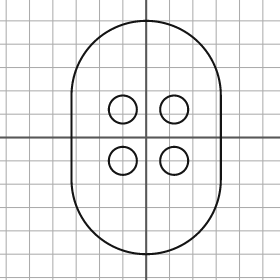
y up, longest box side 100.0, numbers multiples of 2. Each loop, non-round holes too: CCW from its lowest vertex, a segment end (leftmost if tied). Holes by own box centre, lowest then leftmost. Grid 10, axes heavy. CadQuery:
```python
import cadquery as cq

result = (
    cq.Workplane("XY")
    .moveTo(-32.0, -18.0)
    .threePointArc((0.0, -50.0), (32.0, -18.0))
    .lineTo(32.0, 18.0)
    .threePointArc((0.0, 50.0), (-32.0, 18.0))
    .close()
    .moveTo(-10.0, -10.0)
    .circle(6.0)
    .moveTo(12.0, -10.0)
    .circle(6.0)
    .moveTo(-10.0, 12.0)
    .circle(6.0)
    .moveTo(12.0, 12.0)
    .circle(6.0)
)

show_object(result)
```